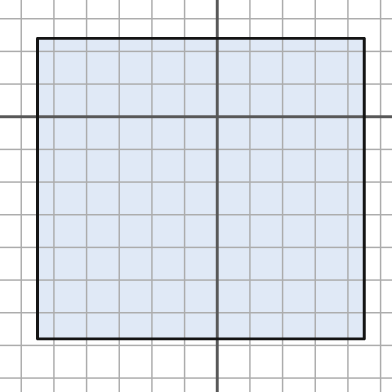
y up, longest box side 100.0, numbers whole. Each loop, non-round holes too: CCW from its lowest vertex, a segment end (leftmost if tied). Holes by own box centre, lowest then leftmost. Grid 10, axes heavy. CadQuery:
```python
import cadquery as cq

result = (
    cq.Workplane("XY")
    .moveTo(-55.0, -68.0)
    .lineTo(45.0, -68.0)
    .lineTo(45.0, 24.0)
    .lineTo(-55.0, 24.0)
    .close()
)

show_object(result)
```